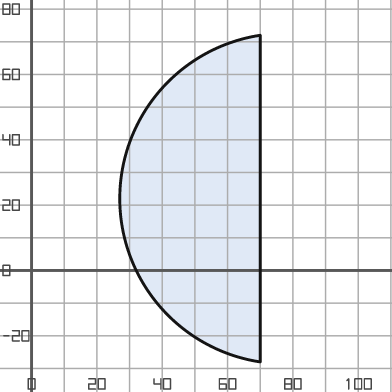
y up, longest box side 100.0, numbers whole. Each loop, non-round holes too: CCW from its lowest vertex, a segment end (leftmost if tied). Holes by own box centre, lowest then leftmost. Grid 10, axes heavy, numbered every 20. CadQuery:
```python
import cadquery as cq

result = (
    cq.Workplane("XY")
    .moveTo(70.0, -28.0)
    .lineTo(70.0, 72.0)
    .threePointArc((27.0, 22.0), (70.0, -28.0))
    .close()
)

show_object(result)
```